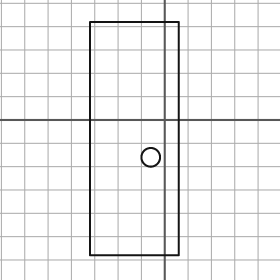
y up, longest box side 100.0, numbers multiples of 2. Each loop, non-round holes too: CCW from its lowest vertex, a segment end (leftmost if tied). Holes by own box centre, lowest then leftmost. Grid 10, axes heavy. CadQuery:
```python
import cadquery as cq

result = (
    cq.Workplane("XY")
    .moveTo(-32.0, -58.0)
    .lineTo(6.0, -58.0)
    .lineTo(6.0, 42.0)
    .lineTo(-32.0, 42.0)
    .close()
    .moveTo(-6.0, -16.0)
    .circle(4.0)
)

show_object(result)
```